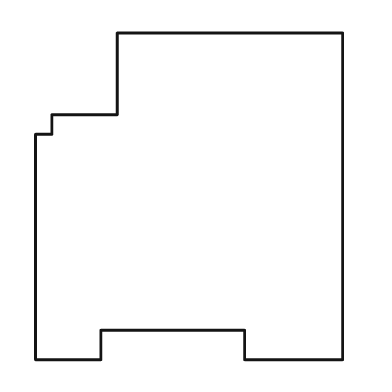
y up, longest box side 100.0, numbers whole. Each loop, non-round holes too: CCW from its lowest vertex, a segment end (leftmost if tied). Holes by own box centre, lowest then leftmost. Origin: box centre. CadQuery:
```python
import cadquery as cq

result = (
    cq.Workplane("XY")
    .moveTo(-47.0, -50.0)
    .lineTo(-27.0, -50.0)
    .lineTo(-27.0, -41.0)
    .lineTo(17.0, -41.0)
    .lineTo(17.0, -50.0)
    .lineTo(47.0, -50.0)
    .lineTo(47.0, 50.0)
    .lineTo(-22.0, 50.0)
    .lineTo(-22.0, 25.0)
    .lineTo(-42.0, 25.0)
    .lineTo(-42.0, 19.0)
    .lineTo(-47.0, 19.0)
    .close()
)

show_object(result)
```